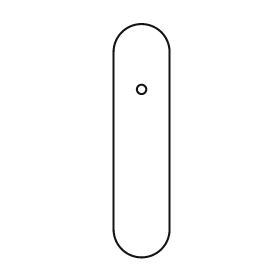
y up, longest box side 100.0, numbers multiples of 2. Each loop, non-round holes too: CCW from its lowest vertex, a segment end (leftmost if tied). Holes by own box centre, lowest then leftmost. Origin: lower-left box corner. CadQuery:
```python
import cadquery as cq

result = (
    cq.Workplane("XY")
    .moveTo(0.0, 12.0)
    .threePointArc((12.0, 0.0), (24.0, 12.0))
    .lineTo(24.0, 88.0)
    .threePointArc((12.0, 100.0), (0.0, 88.0))
    .close()
    .moveTo(12.0, 72.0)
    .circle(2.0)
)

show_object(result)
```